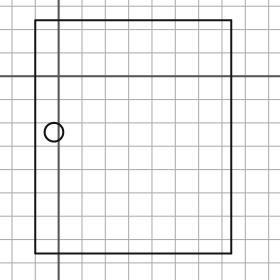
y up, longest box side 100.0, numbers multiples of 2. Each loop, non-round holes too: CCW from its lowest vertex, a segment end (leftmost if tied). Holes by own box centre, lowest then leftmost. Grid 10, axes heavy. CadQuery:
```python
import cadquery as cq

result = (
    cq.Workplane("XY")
    .moveTo(-10.0, -76.0)
    .lineTo(74.0, -76.0)
    .lineTo(74.0, 24.0)
    .lineTo(-10.0, 24.0)
    .close()
    .moveTo(-2.0, -24.0)
    .circle(4.0)
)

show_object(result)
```